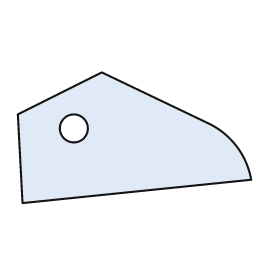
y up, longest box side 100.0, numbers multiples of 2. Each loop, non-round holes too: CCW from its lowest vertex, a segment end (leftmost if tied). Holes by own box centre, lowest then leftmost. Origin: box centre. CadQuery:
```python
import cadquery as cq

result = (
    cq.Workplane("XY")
    .moveTo(-48.0, -28.0)
    .lineTo(50.0, -18.0)
    .threePointArc((44.0, -4.0), (32.0, 6.0))
    .lineTo(-14.0, 28.0)
    .lineTo(-50.0, 10.0)
    .close()
    .moveTo(-26.0, 4.0)
    .circle(6.0)
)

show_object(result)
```